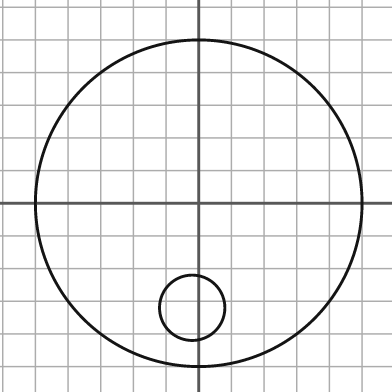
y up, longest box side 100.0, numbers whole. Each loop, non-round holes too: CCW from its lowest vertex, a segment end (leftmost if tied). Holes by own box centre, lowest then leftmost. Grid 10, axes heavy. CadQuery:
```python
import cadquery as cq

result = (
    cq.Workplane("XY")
    .moveTo(0.0, 0.0)
    .circle(50.0)
    .moveTo(-2.0, -32.0)
    .circle(10.0)
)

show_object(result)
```